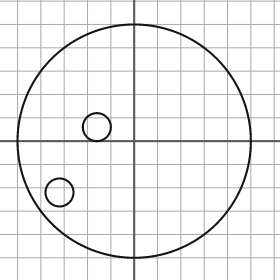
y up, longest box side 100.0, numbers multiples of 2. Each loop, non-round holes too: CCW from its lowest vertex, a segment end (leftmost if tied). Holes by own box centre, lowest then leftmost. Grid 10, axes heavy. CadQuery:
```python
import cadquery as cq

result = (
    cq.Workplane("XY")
    .moveTo(0.0, 0.0)
    .circle(50.0)
    .moveTo(-32.0, -22.0)
    .circle(6.0)
    .moveTo(-16.0, 6.0)
    .circle(6.0)
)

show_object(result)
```